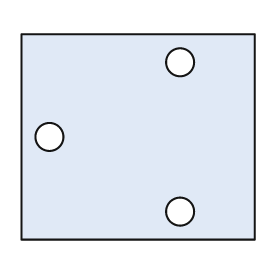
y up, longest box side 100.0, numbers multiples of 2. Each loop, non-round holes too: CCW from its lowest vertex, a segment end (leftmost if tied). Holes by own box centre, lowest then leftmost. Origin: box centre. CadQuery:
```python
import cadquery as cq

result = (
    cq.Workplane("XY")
    .moveTo(-50.0, -44.0)
    .lineTo(50.0, -44.0)
    .lineTo(50.0, 44.0)
    .lineTo(-50.0, 44.0)
    .close()
    .moveTo(18.0, -32.0)
    .circle(6.0)
    .moveTo(-38.0, 0.0)
    .circle(6.0)
    .moveTo(18.0, 32.0)
    .circle(6.0)
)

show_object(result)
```